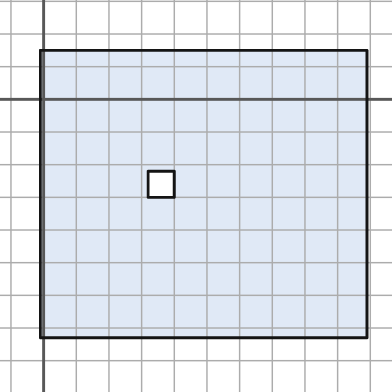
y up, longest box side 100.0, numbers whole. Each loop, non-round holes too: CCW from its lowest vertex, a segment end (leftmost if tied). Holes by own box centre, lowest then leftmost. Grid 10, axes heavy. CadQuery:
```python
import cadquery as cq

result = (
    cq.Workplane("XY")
    .moveTo(-1.0, -73.0)
    .lineTo(99.0, -73.0)
    .lineTo(99.0, 15.0)
    .lineTo(-1.0, 15.0)
    .close()
    .moveTo(32.0, -30.0)
    .lineTo(40.0, -30.0)
    .lineTo(40.0, -22.0)
    .lineTo(32.0, -22.0)
    .close()
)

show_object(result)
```